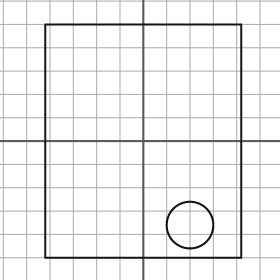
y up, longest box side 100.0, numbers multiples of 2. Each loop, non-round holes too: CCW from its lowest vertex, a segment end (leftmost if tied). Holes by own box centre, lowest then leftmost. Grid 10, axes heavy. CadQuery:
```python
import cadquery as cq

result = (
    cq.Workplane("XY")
    .moveTo(-42.0, -50.0)
    .lineTo(42.0, -50.0)
    .lineTo(42.0, 50.0)
    .lineTo(-42.0, 50.0)
    .close()
    .moveTo(20.0, -36.0)
    .circle(10.0)
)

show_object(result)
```